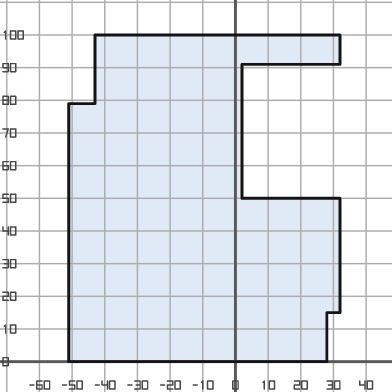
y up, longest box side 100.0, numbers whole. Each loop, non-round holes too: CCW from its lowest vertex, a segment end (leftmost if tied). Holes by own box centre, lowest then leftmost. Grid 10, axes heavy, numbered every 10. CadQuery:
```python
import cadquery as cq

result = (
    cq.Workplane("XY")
    .moveTo(-51.0, 0.0)
    .lineTo(28.0, 0.0)
    .lineTo(28.0, 15.0)
    .lineTo(32.0, 15.0)
    .lineTo(32.0, 50.0)
    .lineTo(2.0, 50.0)
    .lineTo(2.0, 91.0)
    .lineTo(32.0, 91.0)
    .lineTo(32.0, 100.0)
    .lineTo(-43.0, 100.0)
    .lineTo(-43.0, 79.0)
    .lineTo(-51.0, 79.0)
    .close()
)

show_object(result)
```